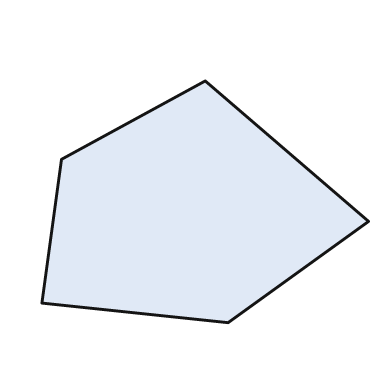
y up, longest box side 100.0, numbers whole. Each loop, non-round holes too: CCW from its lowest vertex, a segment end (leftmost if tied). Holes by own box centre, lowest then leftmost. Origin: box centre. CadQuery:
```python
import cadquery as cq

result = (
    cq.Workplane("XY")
    .moveTo(7.0, -37.0)
    .lineTo(50.0, -6.0)
    .lineTo(0.0, 37.0)
    .lineTo(-44.0, 13.0)
    .lineTo(-50.0, -31.0)
    .close()
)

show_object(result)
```